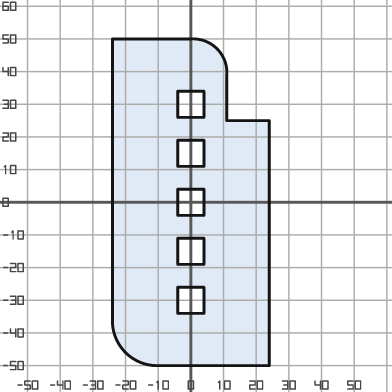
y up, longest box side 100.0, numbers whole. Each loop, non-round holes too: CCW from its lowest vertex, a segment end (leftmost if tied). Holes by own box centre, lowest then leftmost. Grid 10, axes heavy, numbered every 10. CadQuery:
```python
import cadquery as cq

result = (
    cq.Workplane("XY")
    .moveTo(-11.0, -50.0)
    .lineTo(24.0, -50.0)
    .lineTo(24.0, 25.0)
    .lineTo(11.0, 25.0)
    .lineTo(11.0, 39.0)
    .threePointArc((8.0, 47.0), (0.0, 50.0))
    .lineTo(-24.0, 50.0)
    .lineTo(-24.0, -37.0)
    .threePointArc((-20.0, -46.0), (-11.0, -50.0))
    .close()
    .moveTo(-4.0, -34.0)
    .lineTo(4.0, -34.0)
    .lineTo(4.0, -26.0)
    .lineTo(-4.0, -26.0)
    .close()
    .moveTo(-4.0, -19.0)
    .lineTo(4.0, -19.0)
    .lineTo(4.0, -11.0)
    .lineTo(-4.0, -11.0)
    .close()
    .moveTo(-4.0, -4.0)
    .lineTo(4.0, -4.0)
    .lineTo(4.0, 4.0)
    .lineTo(-4.0, 4.0)
    .close()
    .moveTo(-4.0, 11.0)
    .lineTo(4.0, 11.0)
    .lineTo(4.0, 19.0)
    .lineTo(-4.0, 19.0)
    .close()
    .moveTo(-4.0, 26.0)
    .lineTo(4.0, 26.0)
    .lineTo(4.0, 34.0)
    .lineTo(-4.0, 34.0)
    .close()
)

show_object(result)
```